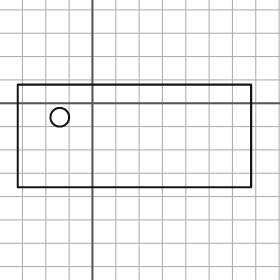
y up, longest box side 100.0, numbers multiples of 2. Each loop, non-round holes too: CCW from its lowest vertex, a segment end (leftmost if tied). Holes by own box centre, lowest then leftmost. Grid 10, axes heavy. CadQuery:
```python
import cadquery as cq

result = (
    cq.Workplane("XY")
    .moveTo(-32.0, -36.0)
    .lineTo(68.0, -36.0)
    .lineTo(68.0, 8.0)
    .lineTo(-32.0, 8.0)
    .close()
    .moveTo(-14.0, -6.0)
    .circle(4.0)
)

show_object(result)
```